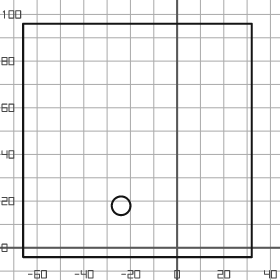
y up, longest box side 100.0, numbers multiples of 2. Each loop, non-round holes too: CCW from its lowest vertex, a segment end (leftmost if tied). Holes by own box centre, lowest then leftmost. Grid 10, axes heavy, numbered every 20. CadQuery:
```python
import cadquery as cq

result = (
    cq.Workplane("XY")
    .moveTo(-66.0, -4.0)
    .lineTo(32.0, -4.0)
    .lineTo(32.0, 96.0)
    .lineTo(-66.0, 96.0)
    .close()
    .moveTo(-24.0, 18.0)
    .circle(4.0)
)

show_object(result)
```